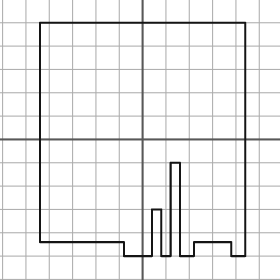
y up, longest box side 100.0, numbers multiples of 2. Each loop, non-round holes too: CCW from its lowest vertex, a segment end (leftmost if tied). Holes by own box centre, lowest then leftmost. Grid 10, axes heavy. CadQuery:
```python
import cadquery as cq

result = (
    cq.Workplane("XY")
    .moveTo(-8.0, -50.0)
    .lineTo(4.0, -50.0)
    .lineTo(4.0, -30.0)
    .lineTo(8.0, -30.0)
    .lineTo(8.0, -50.0)
    .lineTo(12.0, -50.0)
    .lineTo(12.0, -10.0)
    .lineTo(16.0, -10.0)
    .lineTo(16.0, -50.0)
    .lineTo(22.0, -50.0)
    .lineTo(22.0, -44.0)
    .lineTo(38.0, -44.0)
    .lineTo(38.0, -50.0)
    .lineTo(44.0, -50.0)
    .lineTo(44.0, 50.0)
    .lineTo(-44.0, 50.0)
    .lineTo(-44.0, -44.0)
    .lineTo(-8.0, -44.0)
    .close()
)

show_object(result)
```